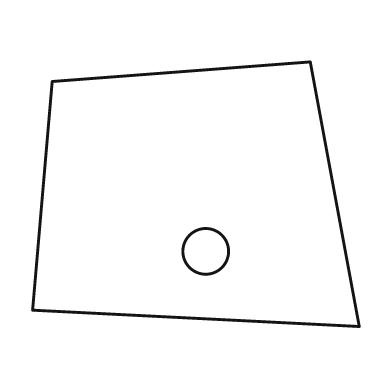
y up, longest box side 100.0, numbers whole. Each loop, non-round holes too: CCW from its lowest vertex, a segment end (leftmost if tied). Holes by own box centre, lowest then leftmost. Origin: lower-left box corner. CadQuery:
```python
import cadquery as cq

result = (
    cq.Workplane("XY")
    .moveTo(100.0, 0.0)
    .lineTo(85.0, 81.0)
    .lineTo(6.0, 75.0)
    .lineTo(0.0, 5.0)
    .close()
    .moveTo(53.0, 23.0)
    .circle(7.0)
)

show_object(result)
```